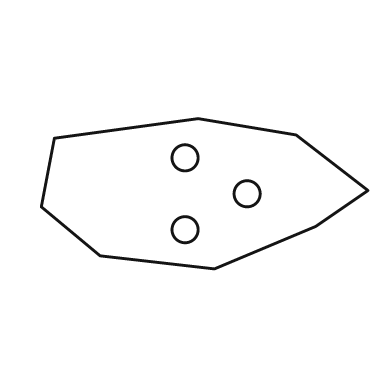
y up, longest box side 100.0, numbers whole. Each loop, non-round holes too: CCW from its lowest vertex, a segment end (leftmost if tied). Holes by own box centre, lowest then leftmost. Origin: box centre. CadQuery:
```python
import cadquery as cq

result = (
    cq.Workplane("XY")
    .moveTo(3.0, -23.0)
    .lineTo(34.0, -10.0)
    .lineTo(50.0, 1.0)
    .lineTo(28.0, 18.0)
    .lineTo(-2.0, 23.0)
    .lineTo(-46.0, 17.0)
    .lineTo(-50.0, -4.0)
    .lineTo(-32.0, -19.0)
    .close()
    .moveTo(-6.0, -11.0)
    .circle(4.0)
    .moveTo(13.0, 0.0)
    .circle(4.0)
    .moveTo(-6.0, 11.0)
    .circle(4.0)
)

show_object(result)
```